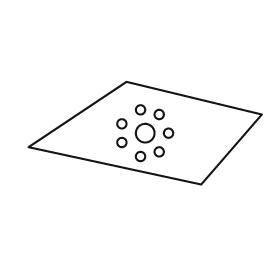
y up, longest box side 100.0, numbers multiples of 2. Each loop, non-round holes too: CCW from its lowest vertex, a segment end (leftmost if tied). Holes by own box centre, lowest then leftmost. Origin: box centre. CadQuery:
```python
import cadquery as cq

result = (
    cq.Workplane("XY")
    .moveTo(24.0, -22.0)
    .lineTo(50.0, 8.0)
    .lineTo(-8.0, 22.0)
    .lineTo(-50.0, -6.0)
    .close()
    .moveTo(-2.0, -10.0)
    .circle(2.0)
    .moveTo(6.0, -8.0)
    .circle(2.0)
    .moveTo(-10.0, -4.0)
    .circle(2.0)
    .moveTo(0.0, 0.0)
    .circle(4.0)
    .moveTo(10.0, 0.0)
    .circle(2.0)
    .moveTo(-10.0, 4.0)
    .circle(2.0)
    .moveTo(6.0, 8.0)
    .circle(2.0)
    .moveTo(-2.0, 10.0)
    .circle(2.0)
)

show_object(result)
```